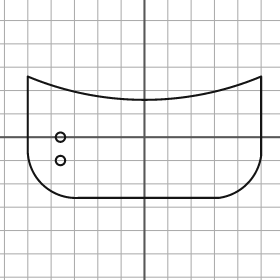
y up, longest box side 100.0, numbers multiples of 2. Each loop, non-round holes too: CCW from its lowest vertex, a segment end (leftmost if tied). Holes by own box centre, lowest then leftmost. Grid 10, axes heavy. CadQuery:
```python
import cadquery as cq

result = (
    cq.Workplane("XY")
    .moveTo(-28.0, -26.0)
    .lineTo(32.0, -26.0)
    .threePointArc((44.0, -20.0), (50.0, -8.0))
    .lineTo(50.0, 26.0)
    .threePointArc((0.0, 16.0), (-50.0, 26.0))
    .lineTo(-50.0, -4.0)
    .threePointArc((-44.0, -20.0), (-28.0, -26.0))
    .close()
    .moveTo(-36.0, -10.0)
    .circle(2.0)
    .moveTo(-36.0, 0.0)
    .circle(2.0)
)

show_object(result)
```